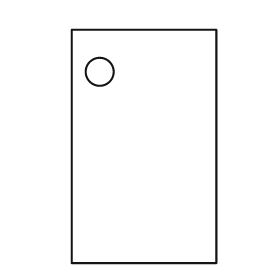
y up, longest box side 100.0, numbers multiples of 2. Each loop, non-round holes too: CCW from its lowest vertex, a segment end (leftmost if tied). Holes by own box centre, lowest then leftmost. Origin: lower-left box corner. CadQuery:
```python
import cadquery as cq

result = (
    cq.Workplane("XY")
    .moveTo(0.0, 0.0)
    .lineTo(62.0, 0.0)
    .lineTo(62.0, 100.0)
    .lineTo(0.0, 100.0)
    .close()
    .moveTo(12.0, 82.0)
    .circle(6.0)
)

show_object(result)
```